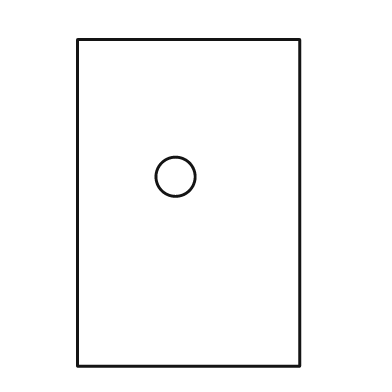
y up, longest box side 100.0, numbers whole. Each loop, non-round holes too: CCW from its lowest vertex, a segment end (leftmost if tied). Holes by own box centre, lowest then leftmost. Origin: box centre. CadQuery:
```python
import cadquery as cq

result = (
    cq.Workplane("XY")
    .moveTo(-34.0, -50.0)
    .lineTo(34.0, -50.0)
    .lineTo(34.0, 50.0)
    .lineTo(-34.0, 50.0)
    .close()
    .moveTo(-4.0, 8.0)
    .circle(6.0)
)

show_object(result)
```